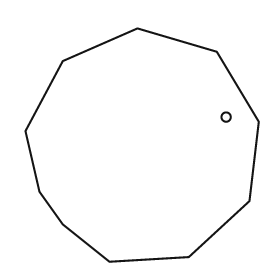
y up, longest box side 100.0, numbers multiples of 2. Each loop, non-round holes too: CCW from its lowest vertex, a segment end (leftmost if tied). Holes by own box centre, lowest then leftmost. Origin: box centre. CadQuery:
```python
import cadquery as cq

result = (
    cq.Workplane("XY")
    .moveTo(-14.0, -50.0)
    .lineTo(20.0, -48.0)
    .lineTo(46.0, -24.0)
    .lineTo(50.0, 10.0)
    .lineTo(32.0, 40.0)
    .lineTo(-2.0, 50.0)
    .lineTo(-34.0, 36.0)
    .lineTo(-50.0, 6.0)
    .lineTo(-44.0, -20.0)
    .lineTo(-34.0, -34.0)
    .close()
    .moveTo(36.0, 12.0)
    .circle(2.0)
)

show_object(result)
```